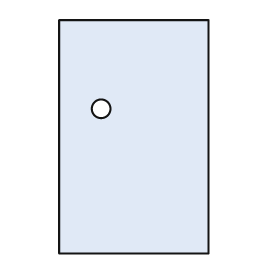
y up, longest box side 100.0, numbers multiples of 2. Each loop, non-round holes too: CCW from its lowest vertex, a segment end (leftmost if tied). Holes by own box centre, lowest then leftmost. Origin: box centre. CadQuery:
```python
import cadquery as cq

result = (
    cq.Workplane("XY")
    .moveTo(-32.0, -50.0)
    .lineTo(32.0, -50.0)
    .lineTo(32.0, 50.0)
    .lineTo(-32.0, 50.0)
    .close()
    .moveTo(-14.0, 12.0)
    .circle(4.0)
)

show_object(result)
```